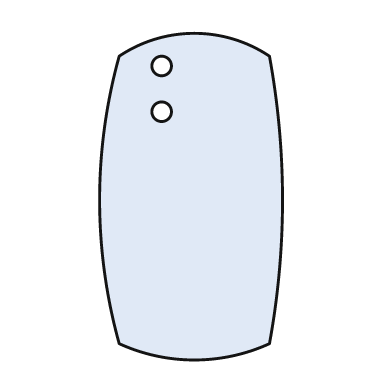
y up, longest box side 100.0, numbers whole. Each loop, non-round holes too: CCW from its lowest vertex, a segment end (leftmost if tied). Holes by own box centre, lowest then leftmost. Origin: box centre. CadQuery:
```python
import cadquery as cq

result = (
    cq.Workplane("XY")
    .moveTo(-22.0, -45.0)
    .threePointArc((1.0, -50.0), (24.0, -45.0))
    .threePointArc((28.0, -1.0), (24.0, 43.0))
    .threePointArc((1.0, 50.0), (-22.0, 43.0))
    .threePointArc((-28.0, -1.0), (-22.0, -45.0))
    .close()
    .moveTo(-9.0, 26.0)
    .circle(3.0)
    .moveTo(-9.0, 40.0)
    .circle(3.0)
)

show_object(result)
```